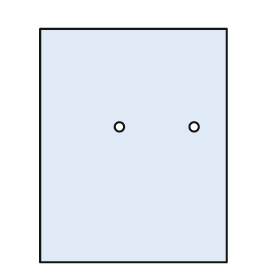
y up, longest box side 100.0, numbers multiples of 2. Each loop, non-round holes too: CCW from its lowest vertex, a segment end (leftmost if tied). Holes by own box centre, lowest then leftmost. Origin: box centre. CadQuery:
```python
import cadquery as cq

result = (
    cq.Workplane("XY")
    .moveTo(-40.0, -50.0)
    .lineTo(40.0, -50.0)
    .lineTo(40.0, 50.0)
    .lineTo(-40.0, 50.0)
    .close()
    .moveTo(-6.0, 8.0)
    .circle(2.0)
    .moveTo(26.0, 8.0)
    .circle(2.0)
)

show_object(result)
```